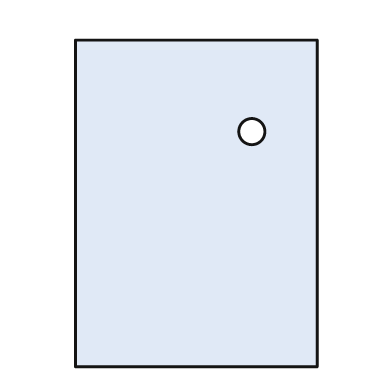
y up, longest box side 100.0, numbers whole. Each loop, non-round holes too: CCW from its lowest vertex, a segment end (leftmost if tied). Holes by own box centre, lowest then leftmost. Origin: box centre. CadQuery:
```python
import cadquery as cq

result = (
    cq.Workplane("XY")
    .moveTo(-37.0, -50.0)
    .lineTo(37.0, -50.0)
    .lineTo(37.0, 50.0)
    .lineTo(-37.0, 50.0)
    .close()
    .moveTo(17.0, 22.0)
    .circle(4.0)
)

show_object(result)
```